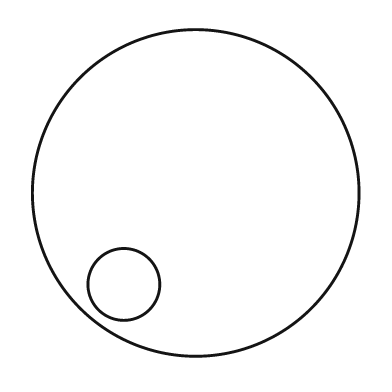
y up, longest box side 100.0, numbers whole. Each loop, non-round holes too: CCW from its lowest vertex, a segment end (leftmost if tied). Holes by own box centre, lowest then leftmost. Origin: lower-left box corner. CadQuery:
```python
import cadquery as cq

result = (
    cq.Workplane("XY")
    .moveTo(50.0, 50.0)
    .circle(50.0)
    .moveTo(28.0, 22.0)
    .circle(11.0)
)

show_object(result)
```